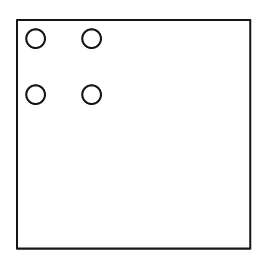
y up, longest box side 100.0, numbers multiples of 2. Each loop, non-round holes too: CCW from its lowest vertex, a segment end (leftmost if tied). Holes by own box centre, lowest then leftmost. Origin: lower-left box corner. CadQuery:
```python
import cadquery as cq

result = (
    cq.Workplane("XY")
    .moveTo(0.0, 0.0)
    .lineTo(100.0, 0.0)
    .lineTo(100.0, 98.0)
    .lineTo(0.0, 98.0)
    .close()
    .moveTo(8.0, 66.0)
    .circle(4.0)
    .moveTo(32.0, 66.0)
    .circle(4.0)
    .moveTo(8.0, 90.0)
    .circle(4.0)
    .moveTo(32.0, 90.0)
    .circle(4.0)
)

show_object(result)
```